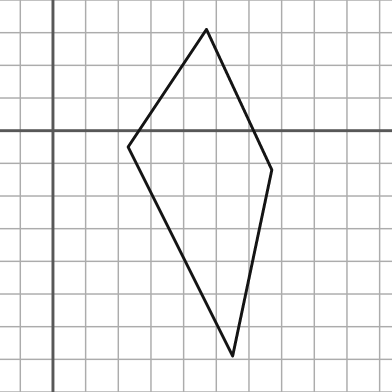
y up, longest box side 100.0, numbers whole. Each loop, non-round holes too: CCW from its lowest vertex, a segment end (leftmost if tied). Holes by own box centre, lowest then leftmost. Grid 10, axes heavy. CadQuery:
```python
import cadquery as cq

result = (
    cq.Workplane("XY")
    .moveTo(55.0, -69.0)
    .lineTo(67.0, -12.0)
    .lineTo(47.0, 31.0)
    .lineTo(23.0, -5.0)
    .close()
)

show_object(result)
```